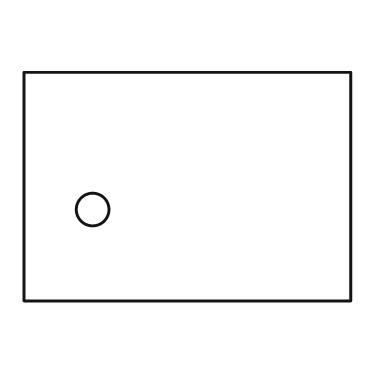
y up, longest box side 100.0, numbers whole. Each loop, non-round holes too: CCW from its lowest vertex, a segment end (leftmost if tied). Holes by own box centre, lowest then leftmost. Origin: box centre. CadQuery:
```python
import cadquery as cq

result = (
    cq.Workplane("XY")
    .moveTo(-50.0, -35.0)
    .lineTo(50.0, -35.0)
    .lineTo(50.0, 35.0)
    .lineTo(-50.0, 35.0)
    .close()
    .moveTo(-29.0, -7.0)
    .circle(5.0)
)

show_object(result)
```